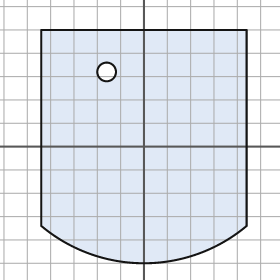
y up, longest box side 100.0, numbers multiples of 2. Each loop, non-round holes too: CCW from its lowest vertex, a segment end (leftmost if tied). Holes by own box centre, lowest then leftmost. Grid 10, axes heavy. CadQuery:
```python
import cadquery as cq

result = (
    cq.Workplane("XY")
    .moveTo(-44.0, -34.0)
    .threePointArc((0.0, -50.0), (44.0, -34.0))
    .lineTo(44.0, 50.0)
    .lineTo(-44.0, 50.0)
    .close()
    .moveTo(-16.0, 32.0)
    .circle(4.0)
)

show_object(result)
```